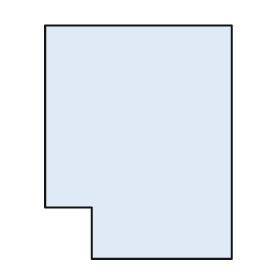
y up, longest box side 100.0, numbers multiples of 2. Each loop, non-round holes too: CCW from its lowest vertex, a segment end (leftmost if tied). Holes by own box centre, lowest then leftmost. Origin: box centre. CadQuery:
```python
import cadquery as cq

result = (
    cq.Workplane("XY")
    .moveTo(-20.0, -50.0)
    .lineTo(40.0, -50.0)
    .lineTo(40.0, 50.0)
    .lineTo(-40.0, 50.0)
    .lineTo(-40.0, -28.0)
    .lineTo(-20.0, -28.0)
    .close()
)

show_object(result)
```